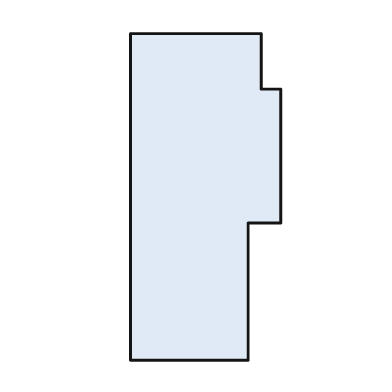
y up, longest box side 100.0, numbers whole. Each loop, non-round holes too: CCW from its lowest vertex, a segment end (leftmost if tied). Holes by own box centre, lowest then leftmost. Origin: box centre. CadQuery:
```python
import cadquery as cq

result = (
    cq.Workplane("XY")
    .moveTo(-23.0, -50.0)
    .lineTo(13.0, -50.0)
    .lineTo(13.0, -8.0)
    .lineTo(23.0, -8.0)
    .lineTo(23.0, 33.0)
    .lineTo(17.0, 33.0)
    .lineTo(17.0, 50.0)
    .lineTo(-23.0, 50.0)
    .close()
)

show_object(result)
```